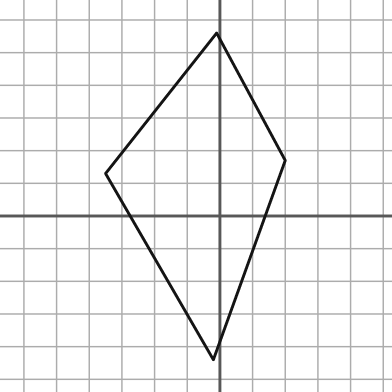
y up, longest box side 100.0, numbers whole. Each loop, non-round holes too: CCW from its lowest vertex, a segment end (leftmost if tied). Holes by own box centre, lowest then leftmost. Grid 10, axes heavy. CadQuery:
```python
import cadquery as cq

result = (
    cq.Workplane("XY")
    .moveTo(-2.0, -44.0)
    .lineTo(20.0, 17.0)
    .lineTo(-1.0, 56.0)
    .lineTo(-35.0, 13.0)
    .close()
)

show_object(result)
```